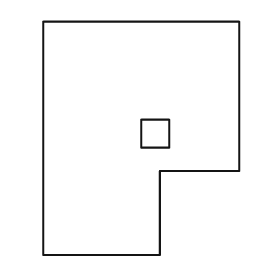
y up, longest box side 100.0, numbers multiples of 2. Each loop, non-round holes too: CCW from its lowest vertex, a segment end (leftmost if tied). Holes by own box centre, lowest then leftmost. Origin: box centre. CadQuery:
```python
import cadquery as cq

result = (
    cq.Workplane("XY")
    .moveTo(-42.0, -50.0)
    .lineTo(8.0, -50.0)
    .lineTo(8.0, -14.0)
    .lineTo(42.0, -14.0)
    .lineTo(42.0, 50.0)
    .lineTo(-42.0, 50.0)
    .close()
    .moveTo(0.0, -4.0)
    .lineTo(12.0, -4.0)
    .lineTo(12.0, 8.0)
    .lineTo(0.0, 8.0)
    .close()
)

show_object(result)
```